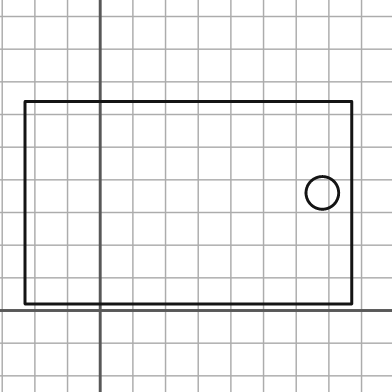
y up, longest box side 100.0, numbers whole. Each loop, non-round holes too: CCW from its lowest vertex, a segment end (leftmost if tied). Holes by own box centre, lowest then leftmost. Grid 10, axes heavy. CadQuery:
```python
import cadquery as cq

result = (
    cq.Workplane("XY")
    .moveTo(-23.0, 2.0)
    .lineTo(77.0, 2.0)
    .lineTo(77.0, 64.0)
    .lineTo(-23.0, 64.0)
    .close()
    .moveTo(68.0, 36.0)
    .circle(5.0)
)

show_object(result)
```